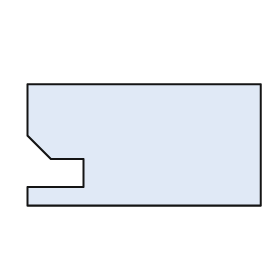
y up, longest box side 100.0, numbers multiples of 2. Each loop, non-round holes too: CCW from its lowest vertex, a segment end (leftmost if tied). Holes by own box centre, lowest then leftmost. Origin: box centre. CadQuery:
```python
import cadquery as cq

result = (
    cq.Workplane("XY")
    .moveTo(-50.0, -26.0)
    .lineTo(50.0, -26.0)
    .lineTo(50.0, 26.0)
    .lineTo(-50.0, 26.0)
    .lineTo(-50.0, 4.0)
    .lineTo(-40.0, -6.0)
    .lineTo(-26.0, -6.0)
    .lineTo(-26.0, -18.0)
    .lineTo(-50.0, -18.0)
    .close()
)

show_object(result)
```